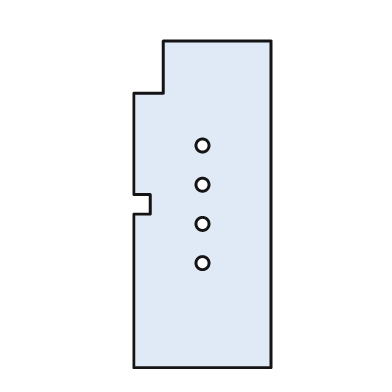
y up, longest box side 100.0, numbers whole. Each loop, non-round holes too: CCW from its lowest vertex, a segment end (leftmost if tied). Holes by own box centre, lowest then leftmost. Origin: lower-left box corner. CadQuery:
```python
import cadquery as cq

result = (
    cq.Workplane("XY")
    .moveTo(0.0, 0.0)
    .lineTo(42.0, 0.0)
    .lineTo(42.0, 100.0)
    .lineTo(9.0, 100.0)
    .lineTo(9.0, 84.0)
    .lineTo(0.0, 84.0)
    .lineTo(0.0, 53.0)
    .lineTo(5.0, 53.0)
    .lineTo(5.0, 47.0)
    .lineTo(0.0, 47.0)
    .close()
    .moveTo(21.0, 32.0)
    .circle(2.0)
    .moveTo(21.0, 44.0)
    .circle(2.0)
    .moveTo(21.0, 56.0)
    .circle(2.0)
    .moveTo(21.0, 68.0)
    .circle(2.0)
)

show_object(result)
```